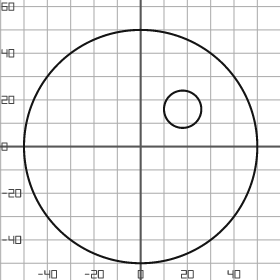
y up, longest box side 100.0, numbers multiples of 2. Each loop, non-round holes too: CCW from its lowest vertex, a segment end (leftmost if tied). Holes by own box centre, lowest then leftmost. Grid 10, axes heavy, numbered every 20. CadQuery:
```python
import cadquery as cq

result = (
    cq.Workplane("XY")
    .moveTo(0.0, 0.0)
    .circle(50.0)
    .moveTo(18.0, 16.0)
    .circle(8.0)
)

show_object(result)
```